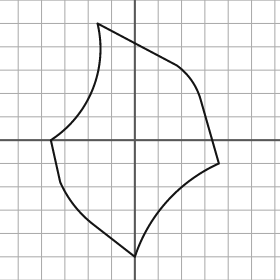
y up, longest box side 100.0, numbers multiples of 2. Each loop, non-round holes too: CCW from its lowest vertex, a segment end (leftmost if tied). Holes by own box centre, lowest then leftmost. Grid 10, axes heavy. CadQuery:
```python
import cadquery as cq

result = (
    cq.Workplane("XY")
    .moveTo(0.0, -50.0)
    .threePointArc((14.0, -26.0), (36.0, -10.0))
    .lineTo(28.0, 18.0)
    .threePointArc((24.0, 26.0), (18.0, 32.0))
    .lineTo(-16.0, 50.0)
    .threePointArc((-18.0, 22.0), (-36.0, 0.0))
    .lineTo(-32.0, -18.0)
    .threePointArc((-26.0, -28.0), (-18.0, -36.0))
    .close()
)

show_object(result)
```